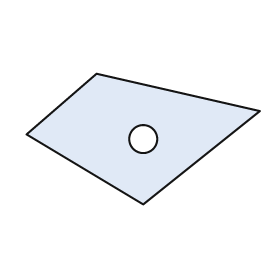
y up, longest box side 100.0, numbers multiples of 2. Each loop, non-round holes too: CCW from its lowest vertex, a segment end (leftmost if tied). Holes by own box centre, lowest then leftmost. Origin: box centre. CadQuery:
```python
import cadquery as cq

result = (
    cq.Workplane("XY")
    .moveTo(0.0, -28.0)
    .lineTo(50.0, 12.0)
    .lineTo(-20.0, 28.0)
    .lineTo(-50.0, 2.0)
    .close()
    .moveTo(0.0, 0.0)
    .circle(6.0)
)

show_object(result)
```